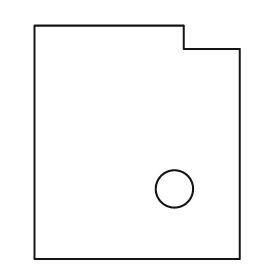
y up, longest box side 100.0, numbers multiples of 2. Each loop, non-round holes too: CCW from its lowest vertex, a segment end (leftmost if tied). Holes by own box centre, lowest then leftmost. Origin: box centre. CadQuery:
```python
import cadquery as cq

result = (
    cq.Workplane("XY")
    .moveTo(-44.0, -50.0)
    .lineTo(44.0, -50.0)
    .lineTo(44.0, 40.0)
    .lineTo(20.0, 40.0)
    .lineTo(20.0, 50.0)
    .lineTo(-44.0, 50.0)
    .close()
    .moveTo(16.0, -20.0)
    .circle(8.0)
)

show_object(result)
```